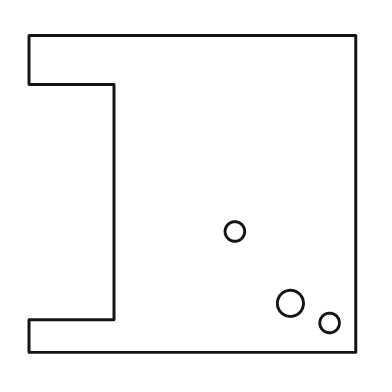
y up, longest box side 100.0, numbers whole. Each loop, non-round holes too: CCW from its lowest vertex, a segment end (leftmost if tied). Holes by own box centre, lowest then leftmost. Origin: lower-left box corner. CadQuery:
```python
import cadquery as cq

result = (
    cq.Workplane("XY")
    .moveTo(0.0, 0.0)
    .lineTo(100.0, 0.0)
    .lineTo(100.0, 97.0)
    .lineTo(0.0, 97.0)
    .lineTo(0.0, 82.0)
    .lineTo(26.0, 82.0)
    .lineTo(26.0, 10.0)
    .lineTo(0.0, 10.0)
    .close()
    .moveTo(92.0, 9.0)
    .circle(3.0)
    .moveTo(80.0, 15.0)
    .circle(4.0)
    .moveTo(63.0, 37.0)
    .circle(3.0)
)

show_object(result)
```